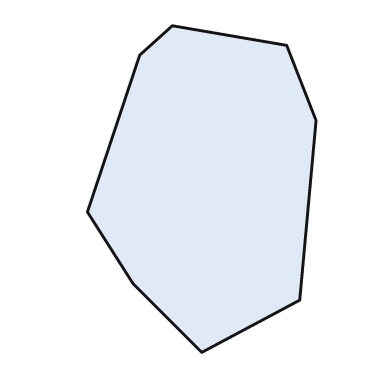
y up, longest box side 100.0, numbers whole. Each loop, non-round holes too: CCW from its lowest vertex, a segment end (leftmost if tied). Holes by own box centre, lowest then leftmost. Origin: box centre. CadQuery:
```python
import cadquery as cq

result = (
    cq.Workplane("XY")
    .moveTo(0.0, -50.0)
    .lineTo(30.0, -34.0)
    .lineTo(35.0, 21.0)
    .lineTo(26.0, 44.0)
    .lineTo(-9.0, 50.0)
    .lineTo(-19.0, 41.0)
    .lineTo(-35.0, -7.0)
    .lineTo(-21.0, -29.0)
    .close()
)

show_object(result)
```